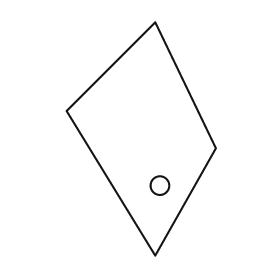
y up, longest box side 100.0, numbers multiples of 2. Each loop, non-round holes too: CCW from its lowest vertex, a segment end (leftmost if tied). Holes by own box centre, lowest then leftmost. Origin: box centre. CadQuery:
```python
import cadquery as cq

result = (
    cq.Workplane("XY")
    .moveTo(6.0, -50.0)
    .lineTo(32.0, -4.0)
    .lineTo(6.0, 50.0)
    .lineTo(-32.0, 12.0)
    .close()
    .moveTo(8.0, -20.0)
    .circle(4.0)
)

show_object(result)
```